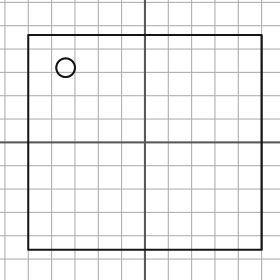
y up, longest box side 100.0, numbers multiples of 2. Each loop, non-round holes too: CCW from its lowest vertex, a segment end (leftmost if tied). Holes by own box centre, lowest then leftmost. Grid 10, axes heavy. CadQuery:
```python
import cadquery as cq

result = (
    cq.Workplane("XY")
    .moveTo(-50.0, -46.0)
    .lineTo(50.0, -46.0)
    .lineTo(50.0, 46.0)
    .lineTo(-50.0, 46.0)
    .close()
    .moveTo(-34.0, 32.0)
    .circle(4.0)
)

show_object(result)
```